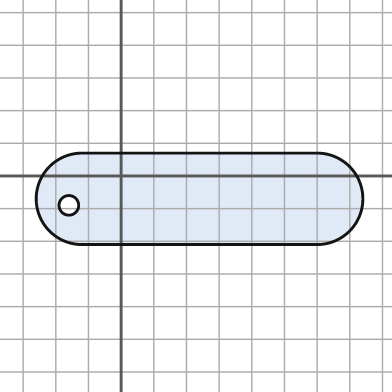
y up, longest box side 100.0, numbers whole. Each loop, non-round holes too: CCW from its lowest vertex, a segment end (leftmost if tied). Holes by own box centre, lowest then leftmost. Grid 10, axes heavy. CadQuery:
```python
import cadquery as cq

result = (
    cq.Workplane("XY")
    .moveTo(-12.0, -21.0)
    .lineTo(60.0, -21.0)
    .threePointArc((74.0, -7.0), (60.0, 7.0))
    .lineTo(-12.0, 7.0)
    .threePointArc((-26.0, -7.0), (-12.0, -21.0))
    .close()
    .moveTo(-16.0, -9.0)
    .circle(3.0)
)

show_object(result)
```